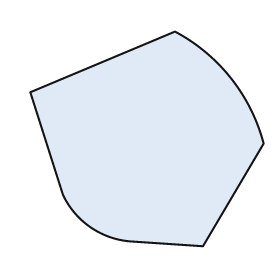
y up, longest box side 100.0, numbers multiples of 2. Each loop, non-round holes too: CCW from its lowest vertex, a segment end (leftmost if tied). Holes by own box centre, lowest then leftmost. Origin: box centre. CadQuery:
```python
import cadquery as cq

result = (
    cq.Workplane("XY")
    .moveTo(24.0, -46.0)
    .lineTo(50.0, -2.0)
    .threePointArc((36.0, 26.0), (12.0, 46.0))
    .lineTo(-50.0, 20.0)
    .lineTo(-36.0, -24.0)
    .threePointArc((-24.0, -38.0), (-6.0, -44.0))
    .close()
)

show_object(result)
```